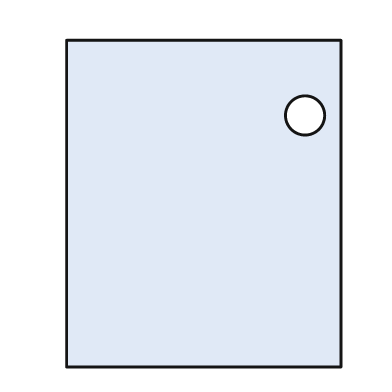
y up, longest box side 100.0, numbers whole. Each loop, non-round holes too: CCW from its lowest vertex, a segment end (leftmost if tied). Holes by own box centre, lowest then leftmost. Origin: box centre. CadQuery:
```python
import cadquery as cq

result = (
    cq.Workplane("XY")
    .moveTo(-42.0, -50.0)
    .lineTo(42.0, -50.0)
    .lineTo(42.0, 50.0)
    .lineTo(-42.0, 50.0)
    .close()
    .moveTo(31.0, 27.0)
    .circle(6.0)
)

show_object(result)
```